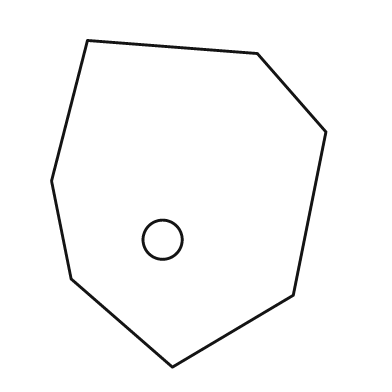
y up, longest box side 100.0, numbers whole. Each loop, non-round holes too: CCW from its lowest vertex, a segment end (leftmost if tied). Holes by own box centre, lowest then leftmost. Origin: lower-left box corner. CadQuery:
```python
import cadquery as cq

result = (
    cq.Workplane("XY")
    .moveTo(37.0, 0.0)
    .lineTo(74.0, 22.0)
    .lineTo(84.0, 72.0)
    .lineTo(63.0, 96.0)
    .lineTo(11.0, 100.0)
    .lineTo(0.0, 57.0)
    .lineTo(6.0, 27.0)
    .close()
    .moveTo(34.0, 39.0)
    .circle(6.0)
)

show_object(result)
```